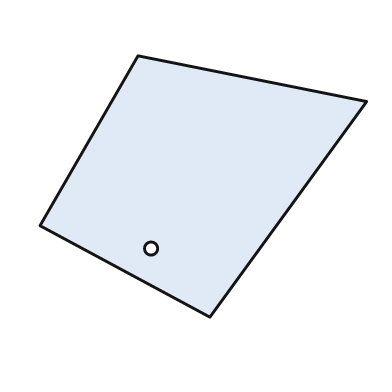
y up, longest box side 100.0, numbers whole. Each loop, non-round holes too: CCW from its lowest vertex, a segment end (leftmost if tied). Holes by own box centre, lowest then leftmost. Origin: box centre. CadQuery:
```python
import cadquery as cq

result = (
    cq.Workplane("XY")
    .moveTo(2.0, -40.0)
    .lineTo(50.0, 26.0)
    .lineTo(-20.0, 40.0)
    .lineTo(-50.0, -12.0)
    .close()
    .moveTo(-16.0, -19.0)
    .circle(2.0)
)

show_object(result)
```